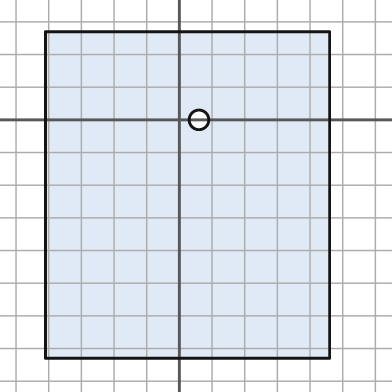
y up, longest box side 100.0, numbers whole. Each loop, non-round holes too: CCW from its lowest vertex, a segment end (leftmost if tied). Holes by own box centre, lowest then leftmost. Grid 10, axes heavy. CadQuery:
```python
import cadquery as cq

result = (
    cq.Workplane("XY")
    .moveTo(-41.0, -73.0)
    .lineTo(46.0, -73.0)
    .lineTo(46.0, 27.0)
    .lineTo(-41.0, 27.0)
    .close()
    .moveTo(6.0, 0.0)
    .circle(3.0)
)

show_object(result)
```